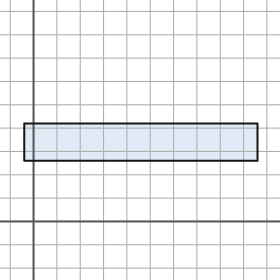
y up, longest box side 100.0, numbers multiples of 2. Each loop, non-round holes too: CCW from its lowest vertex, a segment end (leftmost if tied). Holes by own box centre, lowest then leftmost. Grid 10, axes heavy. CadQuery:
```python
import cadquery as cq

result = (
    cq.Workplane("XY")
    .moveTo(-4.0, 26.0)
    .lineTo(96.0, 26.0)
    .lineTo(96.0, 42.0)
    .lineTo(-4.0, 42.0)
    .close()
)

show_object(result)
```